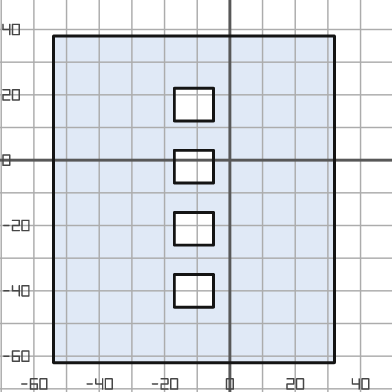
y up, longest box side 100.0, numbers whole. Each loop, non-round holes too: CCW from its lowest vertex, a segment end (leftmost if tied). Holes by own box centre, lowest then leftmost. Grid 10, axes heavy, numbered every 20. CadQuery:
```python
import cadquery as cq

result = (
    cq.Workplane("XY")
    .moveTo(-54.0, -62.0)
    .lineTo(32.0, -62.0)
    .lineTo(32.0, 38.0)
    .lineTo(-54.0, 38.0)
    .close()
    .moveTo(-17.0, -45.0)
    .lineTo(-5.0, -45.0)
    .lineTo(-5.0, -35.0)
    .lineTo(-17.0, -35.0)
    .close()
    .moveTo(-17.0, -26.0)
    .lineTo(-5.0, -26.0)
    .lineTo(-5.0, -16.0)
    .lineTo(-17.0, -16.0)
    .close()
    .moveTo(-17.0, -7.0)
    .lineTo(-5.0, -7.0)
    .lineTo(-5.0, 3.0)
    .lineTo(-17.0, 3.0)
    .close()
    .moveTo(-17.0, 12.0)
    .lineTo(-5.0, 12.0)
    .lineTo(-5.0, 22.0)
    .lineTo(-17.0, 22.0)
    .close()
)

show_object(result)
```